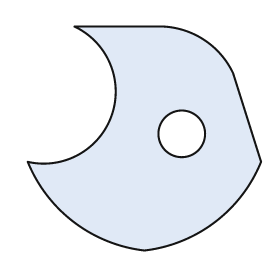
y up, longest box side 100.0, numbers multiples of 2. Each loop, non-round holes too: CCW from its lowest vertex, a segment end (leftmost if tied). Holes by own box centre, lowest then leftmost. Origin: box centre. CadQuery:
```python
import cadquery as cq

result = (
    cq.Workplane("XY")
    .moveTo(0.0, -48.0)
    .threePointArc((30.0, -36.0), (50.0, -10.0))
    .lineTo(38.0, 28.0)
    .threePointArc((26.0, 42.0), (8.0, 48.0))
    .lineTo(-30.0, 48.0)
    .threePointArc((-14.0, 10.0), (-50.0, -10.0))
    .threePointArc((-30.0, -36.0), (0.0, -48.0))
    .close()
    .moveTo(16.0, 2.0)
    .circle(10.0)
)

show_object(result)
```